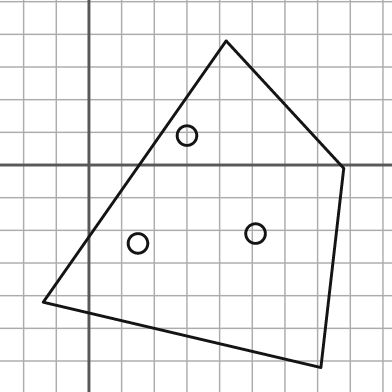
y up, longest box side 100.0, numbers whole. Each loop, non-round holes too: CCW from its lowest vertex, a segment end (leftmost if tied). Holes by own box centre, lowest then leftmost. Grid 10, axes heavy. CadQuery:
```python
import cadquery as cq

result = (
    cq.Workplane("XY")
    .moveTo(71.0, -62.0)
    .lineTo(78.0, -1.0)
    .lineTo(42.0, 38.0)
    .lineTo(-14.0, -42.0)
    .close()
    .moveTo(15.0, -24.0)
    .circle(3.0)
    .moveTo(51.0, -21.0)
    .circle(3.0)
    .moveTo(30.0, 9.0)
    .circle(3.0)
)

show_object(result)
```